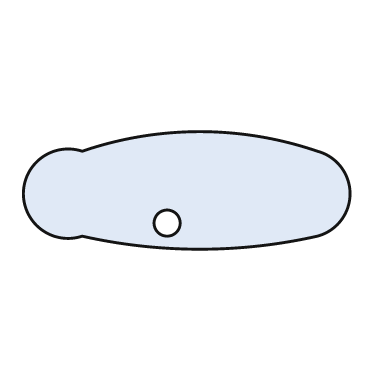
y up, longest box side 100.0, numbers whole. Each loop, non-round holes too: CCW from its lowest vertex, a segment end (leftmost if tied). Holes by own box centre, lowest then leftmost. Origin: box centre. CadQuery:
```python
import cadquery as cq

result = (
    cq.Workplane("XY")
    .moveTo(-32.0, -14.0)
    .threePointArc((4.0, -18.0), (40.0, -14.0))
    .threePointArc((50.0, -1.0), (40.0, 12.0))
    .threePointArc((4.0, 18.0), (-32.0, 12.0))
    .threePointArc((-50.0, -1.0), (-32.0, -14.0))
    .close()
    .moveTo(-6.0, -10.0)
    .circle(4.0)
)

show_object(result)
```